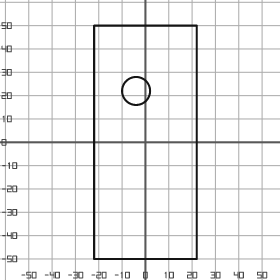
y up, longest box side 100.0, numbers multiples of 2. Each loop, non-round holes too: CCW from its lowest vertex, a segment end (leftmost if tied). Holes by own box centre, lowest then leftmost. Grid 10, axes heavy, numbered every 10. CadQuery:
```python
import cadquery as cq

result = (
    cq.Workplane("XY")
    .moveTo(-22.0, -50.0)
    .lineTo(22.0, -50.0)
    .lineTo(22.0, 50.0)
    .lineTo(-22.0, 50.0)
    .close()
    .moveTo(-4.0, 22.0)
    .circle(6.0)
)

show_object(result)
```